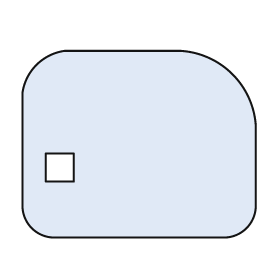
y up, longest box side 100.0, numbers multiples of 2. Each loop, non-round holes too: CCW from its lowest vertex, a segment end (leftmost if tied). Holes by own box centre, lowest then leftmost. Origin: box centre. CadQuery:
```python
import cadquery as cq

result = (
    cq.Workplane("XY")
    .moveTo(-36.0, -40.0)
    .lineTo(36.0, -40.0)
    .threePointArc((46.0, -36.0), (50.0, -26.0))
    .lineTo(50.0, 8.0)
    .threePointArc((40.0, 30.0), (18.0, 40.0))
    .lineTo(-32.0, 40.0)
    .threePointArc((-44.0, 34.0), (-50.0, 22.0))
    .lineTo(-50.0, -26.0)
    .threePointArc((-46.0, -36.0), (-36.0, -40.0))
    .close()
    .moveTo(-40.0, -16.0)
    .lineTo(-28.0, -16.0)
    .lineTo(-28.0, -4.0)
    .lineTo(-40.0, -4.0)
    .close()
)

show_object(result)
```